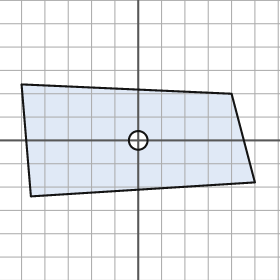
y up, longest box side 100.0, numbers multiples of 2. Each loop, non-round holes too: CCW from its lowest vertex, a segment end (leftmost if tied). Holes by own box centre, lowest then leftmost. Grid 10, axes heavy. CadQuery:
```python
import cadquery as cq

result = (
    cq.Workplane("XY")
    .moveTo(-46.0, -24.0)
    .lineTo(50.0, -18.0)
    .lineTo(40.0, 20.0)
    .lineTo(-50.0, 24.0)
    .close()
    .moveTo(0.0, 0.0)
    .circle(4.0)
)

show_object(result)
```